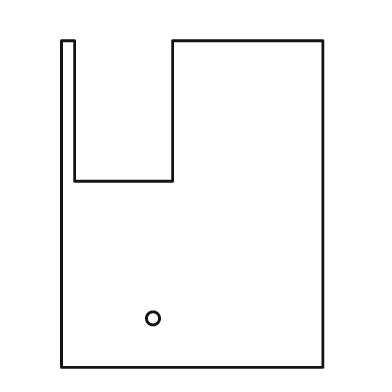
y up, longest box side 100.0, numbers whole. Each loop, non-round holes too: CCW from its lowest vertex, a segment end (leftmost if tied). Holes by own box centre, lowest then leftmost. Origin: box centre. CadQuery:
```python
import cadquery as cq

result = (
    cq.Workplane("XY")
    .moveTo(-40.0, -50.0)
    .lineTo(40.0, -50.0)
    .lineTo(40.0, 50.0)
    .lineTo(-6.0, 50.0)
    .lineTo(-6.0, 7.0)
    .lineTo(-36.0, 7.0)
    .lineTo(-36.0, 50.0)
    .lineTo(-40.0, 50.0)
    .close()
    .moveTo(-12.0, -35.0)
    .circle(2.0)
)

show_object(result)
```